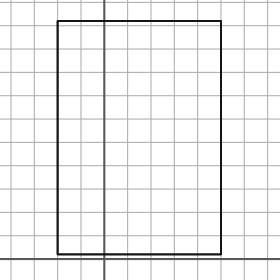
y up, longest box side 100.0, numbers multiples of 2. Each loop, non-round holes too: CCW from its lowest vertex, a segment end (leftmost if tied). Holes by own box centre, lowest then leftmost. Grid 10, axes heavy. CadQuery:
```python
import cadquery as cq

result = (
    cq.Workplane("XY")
    .moveTo(-20.0, 2.0)
    .lineTo(50.0, 2.0)
    .lineTo(50.0, 102.0)
    .lineTo(-20.0, 102.0)
    .close()
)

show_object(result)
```